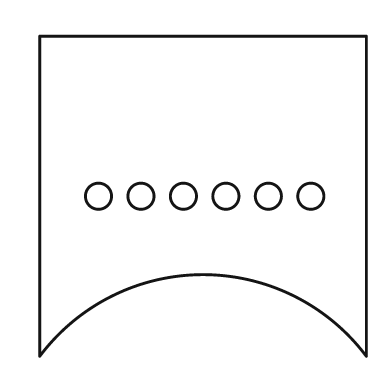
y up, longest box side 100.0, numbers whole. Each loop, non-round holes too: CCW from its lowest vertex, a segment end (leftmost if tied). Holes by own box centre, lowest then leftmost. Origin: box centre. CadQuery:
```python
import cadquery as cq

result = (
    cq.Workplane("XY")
    .moveTo(-50.0, -49.0)
    .threePointArc((0.0, -24.0), (50.0, -49.0))
    .lineTo(50.0, 49.0)
    .lineTo(-50.0, 49.0)
    .close()
    .moveTo(-32.0, 0.0)
    .circle(4.0)
    .moveTo(-19.0, 0.0)
    .circle(4.0)
    .moveTo(-6.0, 0.0)
    .circle(4.0)
    .moveTo(7.0, 0.0)
    .circle(4.0)
    .moveTo(20.0, 0.0)
    .circle(4.0)
    .moveTo(33.0, 0.0)
    .circle(4.0)
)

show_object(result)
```